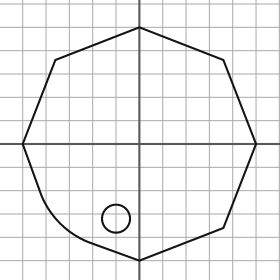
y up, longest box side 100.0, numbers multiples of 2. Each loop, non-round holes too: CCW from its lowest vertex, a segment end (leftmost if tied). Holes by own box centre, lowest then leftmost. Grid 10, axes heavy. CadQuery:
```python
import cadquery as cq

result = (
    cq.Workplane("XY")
    .moveTo(0.0, -50.0)
    .lineTo(36.0, -36.0)
    .lineTo(50.0, 0.0)
    .lineTo(36.0, 36.0)
    .lineTo(0.0, 50.0)
    .lineTo(-36.0, 36.0)
    .lineTo(-50.0, 0.0)
    .lineTo(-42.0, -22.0)
    .threePointArc((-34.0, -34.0), (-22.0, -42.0))
    .close()
    .moveTo(-10.0, -32.0)
    .circle(6.0)
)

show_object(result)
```